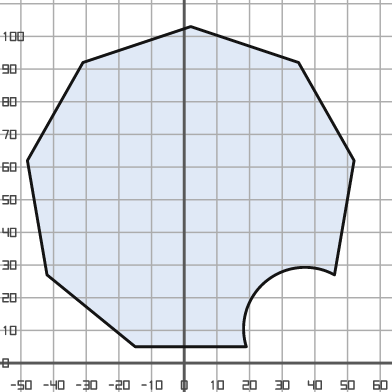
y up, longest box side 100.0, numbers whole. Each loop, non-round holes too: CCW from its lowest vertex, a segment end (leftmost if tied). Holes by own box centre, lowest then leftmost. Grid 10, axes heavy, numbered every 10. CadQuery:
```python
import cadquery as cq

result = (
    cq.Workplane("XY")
    .moveTo(-15.0, 5.0)
    .lineTo(19.0, 5.0)
    .threePointArc((25.0, 25.0), (46.0, 27.0))
    .lineTo(52.0, 62.0)
    .lineTo(35.0, 92.0)
    .lineTo(2.0, 103.0)
    .lineTo(-31.0, 92.0)
    .lineTo(-48.0, 62.0)
    .lineTo(-42.0, 27.0)
    .close()
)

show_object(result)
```